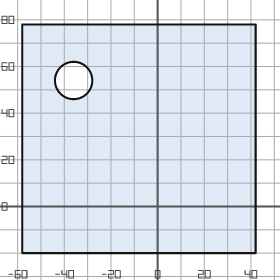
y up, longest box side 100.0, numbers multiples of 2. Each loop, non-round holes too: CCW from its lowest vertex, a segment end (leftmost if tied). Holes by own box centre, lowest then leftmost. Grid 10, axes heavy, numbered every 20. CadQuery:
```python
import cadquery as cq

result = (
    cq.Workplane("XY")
    .moveTo(-58.0, -20.0)
    .lineTo(42.0, -20.0)
    .lineTo(42.0, 78.0)
    .lineTo(-58.0, 78.0)
    .close()
    .moveTo(-36.0, 54.0)
    .circle(8.0)
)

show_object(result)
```